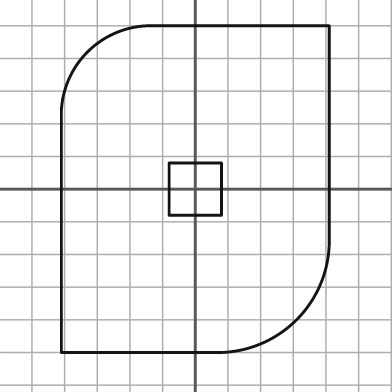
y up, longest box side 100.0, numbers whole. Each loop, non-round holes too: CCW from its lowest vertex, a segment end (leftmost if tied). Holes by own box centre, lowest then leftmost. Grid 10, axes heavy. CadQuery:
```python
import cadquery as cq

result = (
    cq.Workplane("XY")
    .moveTo(-41.0, -50.0)
    .lineTo(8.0, -50.0)
    .threePointArc((31.0, -40.0), (41.0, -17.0))
    .lineTo(41.0, 50.0)
    .lineTo(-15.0, 50.0)
    .threePointArc((-33.0, 42.0), (-41.0, 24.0))
    .close()
    .moveTo(-8.0, -8.0)
    .lineTo(8.0, -8.0)
    .lineTo(8.0, 8.0)
    .lineTo(-8.0, 8.0)
    .close()
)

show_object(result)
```